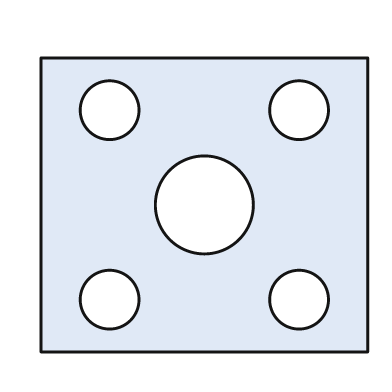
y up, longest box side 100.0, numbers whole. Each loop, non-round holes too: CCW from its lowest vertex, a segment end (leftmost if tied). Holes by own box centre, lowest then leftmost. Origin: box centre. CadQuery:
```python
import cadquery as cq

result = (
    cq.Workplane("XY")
    .moveTo(-50.0, -45.0)
    .lineTo(50.0, -45.0)
    .lineTo(50.0, 45.0)
    .lineTo(-50.0, 45.0)
    .close()
    .moveTo(-29.0, -29.0)
    .circle(9.0)
    .moveTo(29.0, -29.0)
    .circle(9.0)
    .moveTo(0.0, 0.0)
    .circle(15.0)
    .moveTo(-29.0, 29.0)
    .circle(9.0)
    .moveTo(29.0, 29.0)
    .circle(9.0)
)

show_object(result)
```